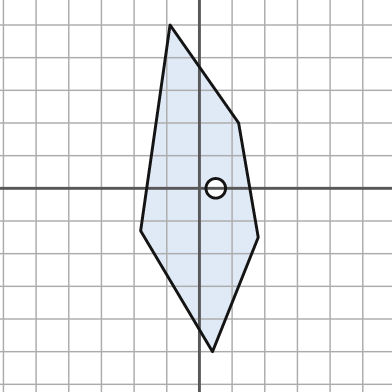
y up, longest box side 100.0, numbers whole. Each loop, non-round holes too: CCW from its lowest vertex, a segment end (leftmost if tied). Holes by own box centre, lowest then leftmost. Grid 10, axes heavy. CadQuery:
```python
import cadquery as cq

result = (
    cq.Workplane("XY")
    .moveTo(4.0, -50.0)
    .lineTo(18.0, -15.0)
    .lineTo(12.0, 20.0)
    .lineTo(-9.0, 50.0)
    .lineTo(-18.0, -13.0)
    .close()
    .moveTo(5.0, 0.0)
    .circle(3.0)
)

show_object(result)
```